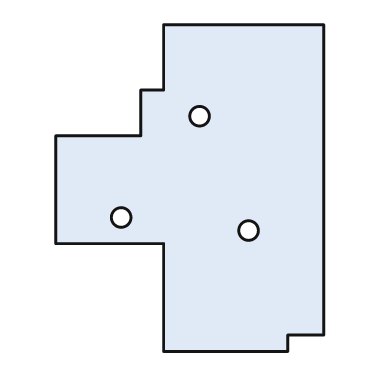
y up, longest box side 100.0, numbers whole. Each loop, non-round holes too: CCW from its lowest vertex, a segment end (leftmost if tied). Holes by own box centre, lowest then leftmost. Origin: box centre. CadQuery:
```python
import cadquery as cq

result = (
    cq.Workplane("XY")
    .moveTo(-8.0, -50.0)
    .lineTo(30.0, -50.0)
    .lineTo(30.0, -45.0)
    .lineTo(41.0, -45.0)
    .lineTo(41.0, 50.0)
    .lineTo(-8.0, 50.0)
    .lineTo(-8.0, 30.0)
    .lineTo(-15.0, 30.0)
    .lineTo(-15.0, 16.0)
    .lineTo(-41.0, 16.0)
    .lineTo(-41.0, -17.0)
    .lineTo(-8.0, -17.0)
    .close()
    .moveTo(18.0, -13.0)
    .circle(3.0)
    .moveTo(-21.0, -9.0)
    .circle(3.0)
    .moveTo(3.0, 22.0)
    .circle(3.0)
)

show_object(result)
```